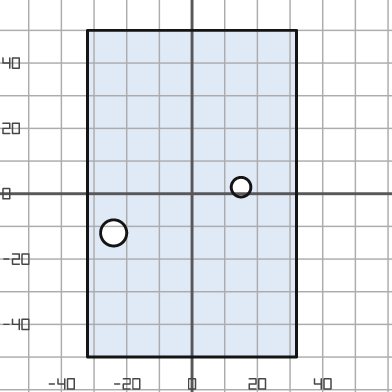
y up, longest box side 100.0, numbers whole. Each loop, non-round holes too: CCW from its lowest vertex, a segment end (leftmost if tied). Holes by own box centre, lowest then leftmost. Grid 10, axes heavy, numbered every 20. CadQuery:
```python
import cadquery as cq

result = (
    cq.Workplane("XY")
    .moveTo(-32.0, -50.0)
    .lineTo(32.0, -50.0)
    .lineTo(32.0, 50.0)
    .lineTo(-32.0, 50.0)
    .close()
    .moveTo(-24.0, -12.0)
    .circle(4.0)
    .moveTo(15.0, 2.0)
    .circle(3.0)
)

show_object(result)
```